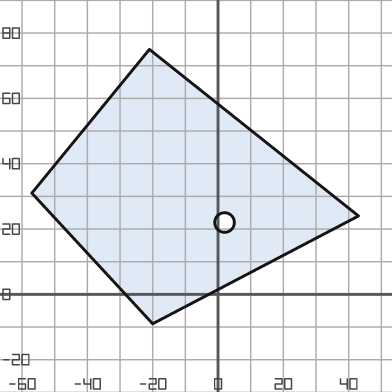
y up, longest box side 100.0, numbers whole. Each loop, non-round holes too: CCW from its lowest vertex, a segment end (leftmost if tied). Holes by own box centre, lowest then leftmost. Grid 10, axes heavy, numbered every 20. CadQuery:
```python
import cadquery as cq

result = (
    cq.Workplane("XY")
    .moveTo(-20.0, -9.0)
    .lineTo(43.0, 24.0)
    .lineTo(-21.0, 75.0)
    .lineTo(-57.0, 31.0)
    .close()
    .moveTo(2.0, 22.0)
    .circle(3.0)
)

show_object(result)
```